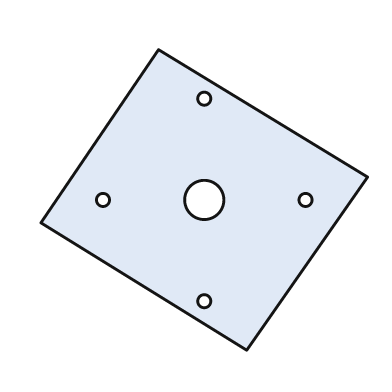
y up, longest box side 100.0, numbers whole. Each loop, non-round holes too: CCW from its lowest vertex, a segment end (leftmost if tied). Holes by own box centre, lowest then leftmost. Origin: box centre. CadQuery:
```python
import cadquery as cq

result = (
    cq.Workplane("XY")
    .moveTo(13.0, -46.0)
    .lineTo(50.0, 7.0)
    .lineTo(-14.0, 46.0)
    .lineTo(-50.0, -7.0)
    .close()
    .moveTo(0.0, -31.0)
    .circle(2.0)
    .moveTo(-31.0, 0.0)
    .circle(2.0)
    .moveTo(0.0, 0.0)
    .circle(6.0)
    .moveTo(31.0, 0.0)
    .circle(2.0)
    .moveTo(0.0, 31.0)
    .circle(2.0)
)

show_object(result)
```